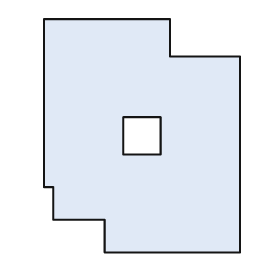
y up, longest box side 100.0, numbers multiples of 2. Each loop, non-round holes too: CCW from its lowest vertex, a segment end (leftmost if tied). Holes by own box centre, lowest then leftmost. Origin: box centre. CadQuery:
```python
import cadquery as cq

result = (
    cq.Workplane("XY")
    .moveTo(-16.0, -50.0)
    .lineTo(42.0, -50.0)
    .lineTo(42.0, 34.0)
    .lineTo(12.0, 34.0)
    .lineTo(12.0, 50.0)
    .lineTo(-42.0, 50.0)
    .lineTo(-42.0, -22.0)
    .lineTo(-38.0, -22.0)
    .lineTo(-38.0, -36.0)
    .lineTo(-16.0, -36.0)
    .close()
    .moveTo(-8.0, -8.0)
    .lineTo(8.0, -8.0)
    .lineTo(8.0, 8.0)
    .lineTo(-8.0, 8.0)
    .close()
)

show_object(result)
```